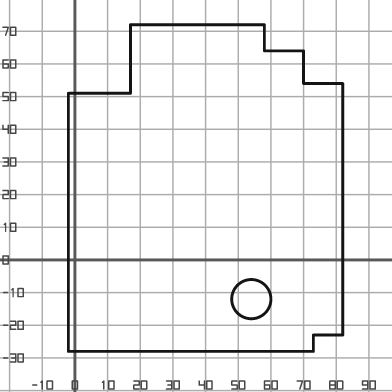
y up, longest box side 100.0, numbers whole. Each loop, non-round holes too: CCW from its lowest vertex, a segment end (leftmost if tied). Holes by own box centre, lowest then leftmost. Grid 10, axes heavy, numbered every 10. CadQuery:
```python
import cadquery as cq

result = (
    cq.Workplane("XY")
    .moveTo(-2.0, -28.0)
    .lineTo(73.0, -28.0)
    .lineTo(73.0, -23.0)
    .lineTo(82.0, -23.0)
    .lineTo(82.0, 54.0)
    .lineTo(70.0, 54.0)
    .lineTo(70.0, 64.0)
    .lineTo(58.0, 64.0)
    .lineTo(58.0, 72.0)
    .lineTo(17.0, 72.0)
    .lineTo(17.0, 51.0)
    .lineTo(-2.0, 51.0)
    .close()
    .moveTo(54.0, -12.0)
    .circle(6.0)
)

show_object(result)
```